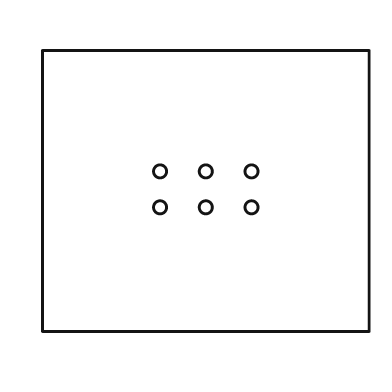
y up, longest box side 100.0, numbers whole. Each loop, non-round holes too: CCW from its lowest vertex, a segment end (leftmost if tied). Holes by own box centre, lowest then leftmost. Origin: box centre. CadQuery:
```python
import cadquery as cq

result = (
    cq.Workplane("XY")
    .moveTo(-50.0, -43.0)
    .lineTo(50.0, -43.0)
    .lineTo(50.0, 43.0)
    .lineTo(-50.0, 43.0)
    .close()
    .moveTo(-14.0, -5.0)
    .circle(2.0)
    .moveTo(0.0, -5.0)
    .circle(2.0)
    .moveTo(14.0, -5.0)
    .circle(2.0)
    .moveTo(-14.0, 6.0)
    .circle(2.0)
    .moveTo(0.0, 6.0)
    .circle(2.0)
    .moveTo(14.0, 6.0)
    .circle(2.0)
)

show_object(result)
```